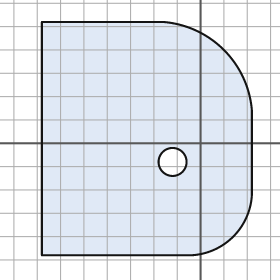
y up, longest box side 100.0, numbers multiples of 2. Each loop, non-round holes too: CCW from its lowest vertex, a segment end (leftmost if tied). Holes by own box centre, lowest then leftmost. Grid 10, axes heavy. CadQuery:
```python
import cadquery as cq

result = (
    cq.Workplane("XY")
    .moveTo(-68.0, -48.0)
    .lineTo(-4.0, -48.0)
    .threePointArc((14.0, -40.0), (22.0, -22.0))
    .lineTo(22.0, 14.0)
    .threePointArc((10.0, 40.0), (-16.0, 52.0))
    .lineTo(-68.0, 52.0)
    .close()
    .moveTo(-12.0, -8.0)
    .circle(6.0)
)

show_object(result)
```